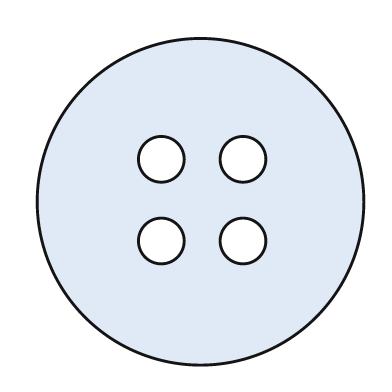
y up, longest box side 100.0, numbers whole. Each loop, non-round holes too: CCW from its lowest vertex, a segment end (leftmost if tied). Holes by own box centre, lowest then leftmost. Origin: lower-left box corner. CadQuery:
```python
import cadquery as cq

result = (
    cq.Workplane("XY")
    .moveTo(50.0, 50.0)
    .circle(50.0)
    .moveTo(38.0, 38.0)
    .circle(7.0)
    .moveTo(63.0, 38.0)
    .circle(7.0)
    .moveTo(38.0, 63.0)
    .circle(7.0)
    .moveTo(63.0, 63.0)
    .circle(7.0)
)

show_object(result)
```